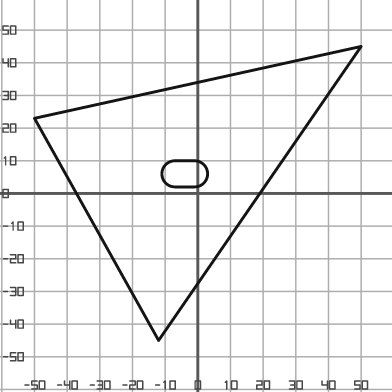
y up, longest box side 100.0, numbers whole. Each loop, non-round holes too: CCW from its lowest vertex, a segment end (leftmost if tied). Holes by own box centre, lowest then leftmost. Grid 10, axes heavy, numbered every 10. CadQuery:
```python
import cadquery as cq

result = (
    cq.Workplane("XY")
    .moveTo(-12.0, -45.0)
    .lineTo(50.0, 45.0)
    .lineTo(-50.0, 23.0)
    .close()
    .moveTo(-7.0, 2.0)
    .lineTo(-1.0, 2.0)
    .threePointArc((3.0, 6.0), (-1.0, 10.0))
    .lineTo(-7.0, 10.0)
    .threePointArc((-11.0, 6.0), (-7.0, 2.0))
    .close()
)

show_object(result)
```